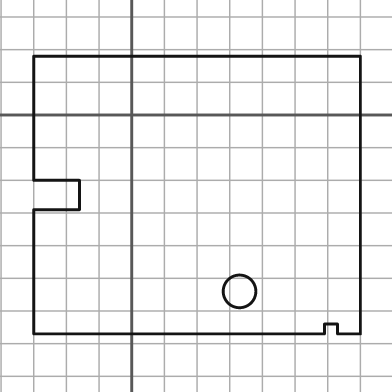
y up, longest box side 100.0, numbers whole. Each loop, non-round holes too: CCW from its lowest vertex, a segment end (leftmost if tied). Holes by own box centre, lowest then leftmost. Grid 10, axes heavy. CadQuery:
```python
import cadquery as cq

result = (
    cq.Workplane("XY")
    .moveTo(-30.0, -67.0)
    .lineTo(59.0, -67.0)
    .lineTo(59.0, -64.0)
    .lineTo(63.0, -64.0)
    .lineTo(63.0, -67.0)
    .lineTo(70.0, -67.0)
    .lineTo(70.0, 18.0)
    .lineTo(-30.0, 18.0)
    .lineTo(-30.0, -20.0)
    .lineTo(-16.0, -20.0)
    .lineTo(-16.0, -29.0)
    .lineTo(-30.0, -29.0)
    .close()
    .moveTo(33.0, -54.0)
    .circle(5.0)
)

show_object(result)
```